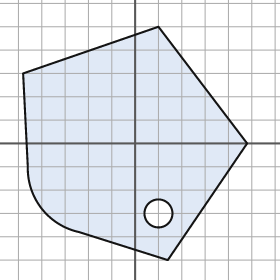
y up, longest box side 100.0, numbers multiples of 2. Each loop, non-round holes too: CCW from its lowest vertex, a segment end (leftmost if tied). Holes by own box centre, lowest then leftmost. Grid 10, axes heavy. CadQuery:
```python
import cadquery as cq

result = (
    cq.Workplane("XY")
    .moveTo(14.0, -50.0)
    .lineTo(48.0, 0.0)
    .lineTo(10.0, 50.0)
    .lineTo(-48.0, 30.0)
    .lineTo(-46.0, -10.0)
    .threePointArc((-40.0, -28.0), (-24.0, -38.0))
    .close()
    .moveTo(10.0, -30.0)
    .circle(6.0)
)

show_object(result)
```